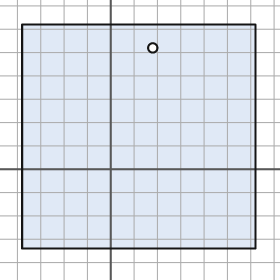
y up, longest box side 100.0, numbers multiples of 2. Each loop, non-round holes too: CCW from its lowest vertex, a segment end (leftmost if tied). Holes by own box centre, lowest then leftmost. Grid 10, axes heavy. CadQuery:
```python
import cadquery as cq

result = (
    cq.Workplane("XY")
    .moveTo(-38.0, -34.0)
    .lineTo(62.0, -34.0)
    .lineTo(62.0, 62.0)
    .lineTo(-38.0, 62.0)
    .close()
    .moveTo(18.0, 52.0)
    .circle(2.0)
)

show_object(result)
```